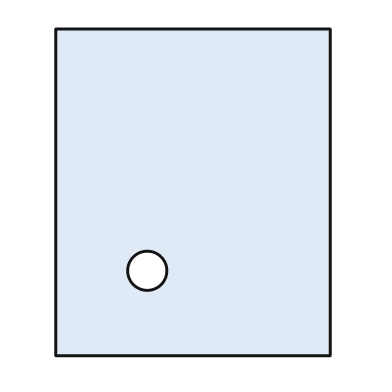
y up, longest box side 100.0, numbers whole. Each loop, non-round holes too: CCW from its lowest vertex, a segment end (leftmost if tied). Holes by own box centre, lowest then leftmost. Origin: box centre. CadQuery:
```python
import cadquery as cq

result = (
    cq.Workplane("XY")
    .moveTo(-42.0, -50.0)
    .lineTo(42.0, -50.0)
    .lineTo(42.0, 50.0)
    .lineTo(-42.0, 50.0)
    .close()
    .moveTo(-14.0, -24.0)
    .circle(6.0)
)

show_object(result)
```